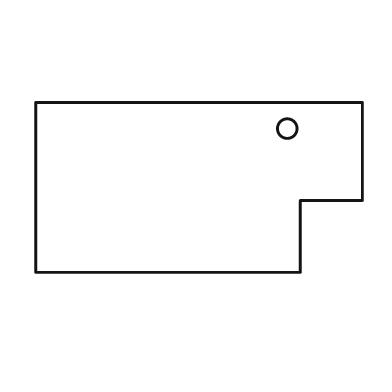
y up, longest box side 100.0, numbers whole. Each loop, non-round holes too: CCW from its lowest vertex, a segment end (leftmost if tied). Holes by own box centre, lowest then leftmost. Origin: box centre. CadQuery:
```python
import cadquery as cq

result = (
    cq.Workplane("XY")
    .moveTo(-50.0, -26.0)
    .lineTo(31.0, -26.0)
    .lineTo(31.0, -4.0)
    .lineTo(50.0, -4.0)
    .lineTo(50.0, 26.0)
    .lineTo(-50.0, 26.0)
    .close()
    .moveTo(27.0, 18.0)
    .circle(3.0)
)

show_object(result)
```